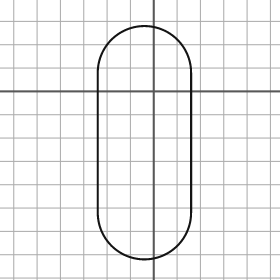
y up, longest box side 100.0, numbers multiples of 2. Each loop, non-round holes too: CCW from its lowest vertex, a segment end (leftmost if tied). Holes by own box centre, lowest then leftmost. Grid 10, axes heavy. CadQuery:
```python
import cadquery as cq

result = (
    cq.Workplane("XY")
    .moveTo(-24.0, -52.0)
    .threePointArc((-4.0, -72.0), (16.0, -52.0))
    .lineTo(16.0, 8.0)
    .threePointArc((-4.0, 28.0), (-24.0, 8.0))
    .close()
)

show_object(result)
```